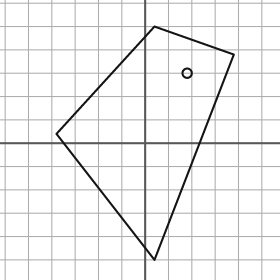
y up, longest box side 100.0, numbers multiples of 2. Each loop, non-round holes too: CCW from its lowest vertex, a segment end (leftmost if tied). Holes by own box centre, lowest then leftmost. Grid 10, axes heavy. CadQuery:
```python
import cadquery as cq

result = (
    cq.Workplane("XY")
    .moveTo(4.0, -50.0)
    .lineTo(38.0, 38.0)
    .lineTo(4.0, 50.0)
    .lineTo(-38.0, 4.0)
    .close()
    .moveTo(18.0, 30.0)
    .circle(2.0)
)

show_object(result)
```